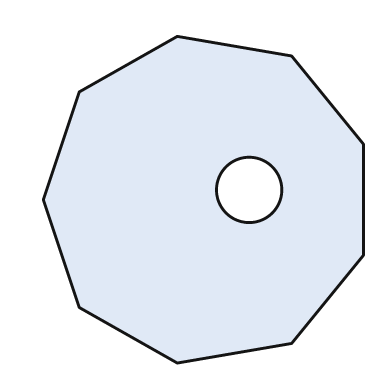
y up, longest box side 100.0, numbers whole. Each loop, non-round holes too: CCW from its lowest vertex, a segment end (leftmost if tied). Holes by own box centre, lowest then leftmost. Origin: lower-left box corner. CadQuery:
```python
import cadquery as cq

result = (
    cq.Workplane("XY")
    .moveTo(41.0, 0.0)
    .lineTo(76.0, 6.0)
    .lineTo(98.0, 33.0)
    .lineTo(98.0, 67.0)
    .lineTo(76.0, 94.0)
    .lineTo(41.0, 100.0)
    .lineTo(11.0, 83.0)
    .lineTo(0.0, 50.0)
    .lineTo(11.0, 17.0)
    .close()
    .moveTo(63.0, 53.0)
    .circle(10.0)
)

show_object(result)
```